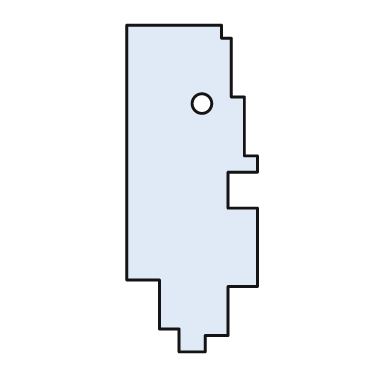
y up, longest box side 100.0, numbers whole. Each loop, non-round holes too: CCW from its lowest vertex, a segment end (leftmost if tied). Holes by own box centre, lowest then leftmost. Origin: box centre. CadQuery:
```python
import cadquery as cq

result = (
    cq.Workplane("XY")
    .moveTo(-4.0, -50.0)
    .lineTo(4.0, -50.0)
    .lineTo(4.0, -45.0)
    .lineTo(11.0, -45.0)
    .lineTo(11.0, -30.0)
    .lineTo(20.0, -30.0)
    .lineTo(20.0, -6.0)
    .lineTo(11.0, -6.0)
    .lineTo(11.0, 5.0)
    .lineTo(20.0, 5.0)
    .lineTo(20.0, 10.0)
    .lineTo(16.0, 10.0)
    .lineTo(16.0, 28.0)
    .lineTo(12.0, 28.0)
    .lineTo(12.0, 46.0)
    .lineTo(9.0, 46.0)
    .lineTo(9.0, 50.0)
    .lineTo(-20.0, 50.0)
    .lineTo(-20.0, -28.0)
    .lineTo(-10.0, -28.0)
    .lineTo(-10.0, -43.0)
    .lineTo(-4.0, -43.0)
    .close()
    .moveTo(3.0, 26.0)
    .circle(3.0)
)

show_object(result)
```